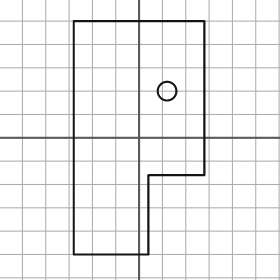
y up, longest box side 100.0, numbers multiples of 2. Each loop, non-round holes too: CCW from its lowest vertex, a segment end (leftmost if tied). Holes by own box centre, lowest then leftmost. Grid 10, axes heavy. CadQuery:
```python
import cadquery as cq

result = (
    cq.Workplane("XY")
    .moveTo(-28.0, -50.0)
    .lineTo(4.0, -50.0)
    .lineTo(4.0, -16.0)
    .lineTo(28.0, -16.0)
    .lineTo(28.0, 50.0)
    .lineTo(-28.0, 50.0)
    .close()
    .moveTo(12.0, 20.0)
    .circle(4.0)
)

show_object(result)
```